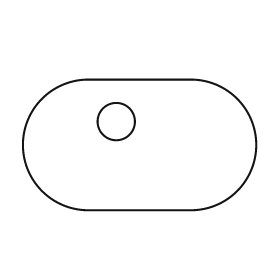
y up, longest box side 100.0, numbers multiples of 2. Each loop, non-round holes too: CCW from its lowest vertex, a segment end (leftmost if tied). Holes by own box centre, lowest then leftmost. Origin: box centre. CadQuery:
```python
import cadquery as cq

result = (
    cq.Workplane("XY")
    .moveTo(-22.0, -28.0)
    .lineTo(22.0, -28.0)
    .threePointArc((50.0, 0.0), (22.0, 28.0))
    .lineTo(-22.0, 28.0)
    .threePointArc((-50.0, 0.0), (-22.0, -28.0))
    .close()
    .moveTo(-10.0, 10.0)
    .circle(8.0)
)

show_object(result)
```